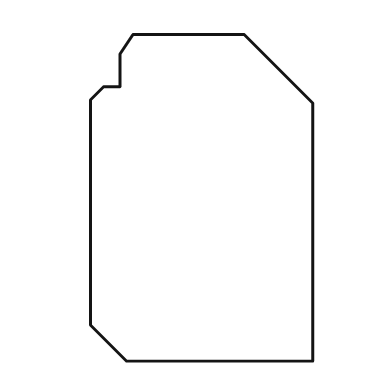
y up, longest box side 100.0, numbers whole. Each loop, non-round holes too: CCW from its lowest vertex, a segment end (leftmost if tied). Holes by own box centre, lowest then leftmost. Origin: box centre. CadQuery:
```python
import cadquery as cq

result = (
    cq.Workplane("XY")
    .moveTo(-23.0, -50.0)
    .lineTo(34.0, -50.0)
    .lineTo(34.0, 29.0)
    .lineTo(13.0, 50.0)
    .lineTo(-21.0, 50.0)
    .lineTo(-25.0, 44.0)
    .lineTo(-25.0, 34.0)
    .lineTo(-30.0, 34.0)
    .lineTo(-34.0, 30.0)
    .lineTo(-34.0, -39.0)
    .close()
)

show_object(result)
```